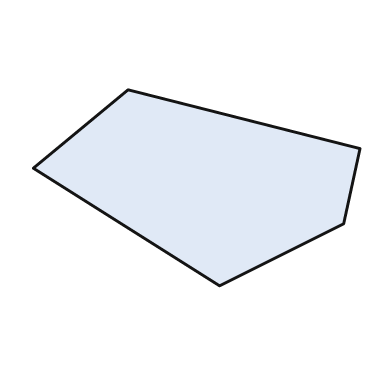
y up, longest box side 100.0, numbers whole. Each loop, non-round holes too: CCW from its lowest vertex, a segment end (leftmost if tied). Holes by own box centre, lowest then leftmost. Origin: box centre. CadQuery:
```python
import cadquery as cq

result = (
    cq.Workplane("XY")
    .moveTo(7.0, -30.0)
    .lineTo(45.0, -11.0)
    .lineTo(50.0, 12.0)
    .lineTo(-21.0, 30.0)
    .lineTo(-50.0, 6.0)
    .close()
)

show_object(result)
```